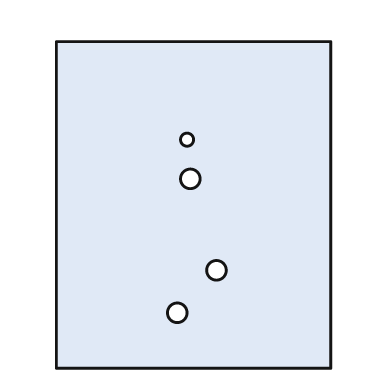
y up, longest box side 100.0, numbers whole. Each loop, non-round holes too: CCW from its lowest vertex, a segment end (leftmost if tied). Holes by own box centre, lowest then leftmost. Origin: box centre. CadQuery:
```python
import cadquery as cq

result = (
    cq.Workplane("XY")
    .moveTo(-42.0, -50.0)
    .lineTo(42.0, -50.0)
    .lineTo(42.0, 50.0)
    .lineTo(-42.0, 50.0)
    .close()
    .moveTo(-5.0, -33.0)
    .circle(3.0)
    .moveTo(7.0, -20.0)
    .circle(3.0)
    .moveTo(-1.0, 8.0)
    .circle(3.0)
    .moveTo(-2.0, 20.0)
    .circle(2.0)
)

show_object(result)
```